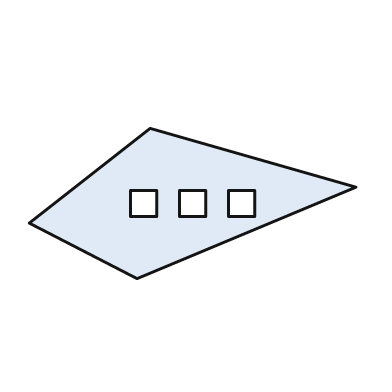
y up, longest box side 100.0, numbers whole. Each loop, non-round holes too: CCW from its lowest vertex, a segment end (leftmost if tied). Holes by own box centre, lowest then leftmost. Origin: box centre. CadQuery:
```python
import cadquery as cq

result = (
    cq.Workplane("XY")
    .moveTo(-17.0, -23.0)
    .lineTo(50.0, 5.0)
    .lineTo(-13.0, 23.0)
    .lineTo(-50.0, -6.0)
    .close()
    .moveTo(-19.0, -4.0)
    .lineTo(-11.0, -4.0)
    .lineTo(-11.0, 4.0)
    .lineTo(-19.0, 4.0)
    .close()
    .moveTo(-4.0, -4.0)
    .lineTo(4.0, -4.0)
    .lineTo(4.0, 4.0)
    .lineTo(-4.0, 4.0)
    .close()
    .moveTo(11.0, -4.0)
    .lineTo(19.0, -4.0)
    .lineTo(19.0, 4.0)
    .lineTo(11.0, 4.0)
    .close()
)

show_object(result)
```